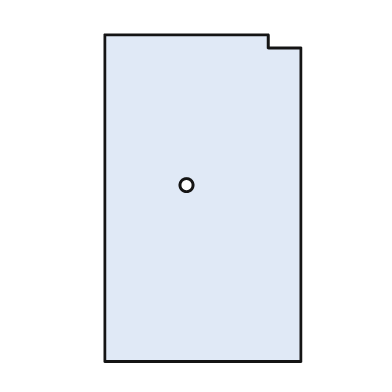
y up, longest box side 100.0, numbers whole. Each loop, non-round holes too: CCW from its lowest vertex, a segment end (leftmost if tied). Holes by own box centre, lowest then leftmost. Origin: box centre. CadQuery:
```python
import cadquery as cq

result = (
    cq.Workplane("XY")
    .moveTo(-30.0, -50.0)
    .lineTo(30.0, -50.0)
    .lineTo(30.0, 46.0)
    .lineTo(20.0, 46.0)
    .lineTo(20.0, 50.0)
    .lineTo(-30.0, 50.0)
    .close()
    .moveTo(-5.0, 4.0)
    .circle(2.0)
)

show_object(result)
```